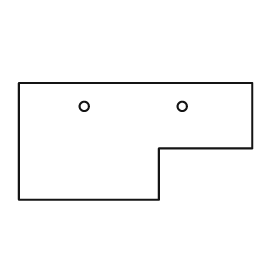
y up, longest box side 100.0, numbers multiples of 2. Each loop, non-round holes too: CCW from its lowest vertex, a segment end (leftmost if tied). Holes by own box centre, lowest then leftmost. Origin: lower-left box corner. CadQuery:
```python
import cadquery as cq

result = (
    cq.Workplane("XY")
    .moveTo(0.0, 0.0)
    .lineTo(60.0, 0.0)
    .lineTo(60.0, 22.0)
    .lineTo(100.0, 22.0)
    .lineTo(100.0, 50.0)
    .lineTo(0.0, 50.0)
    .close()
    .moveTo(28.0, 40.0)
    .circle(2.0)
    .moveTo(70.0, 40.0)
    .circle(2.0)
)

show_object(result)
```